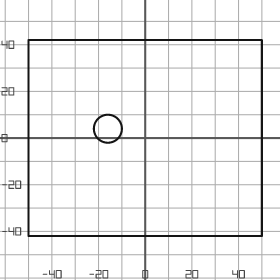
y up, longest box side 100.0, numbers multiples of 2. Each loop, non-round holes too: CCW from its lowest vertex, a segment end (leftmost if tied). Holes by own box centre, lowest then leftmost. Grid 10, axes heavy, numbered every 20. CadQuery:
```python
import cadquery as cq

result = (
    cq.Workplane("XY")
    .moveTo(-50.0, -42.0)
    .lineTo(50.0, -42.0)
    .lineTo(50.0, 42.0)
    .lineTo(-50.0, 42.0)
    .close()
    .moveTo(-16.0, 4.0)
    .circle(6.0)
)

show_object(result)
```